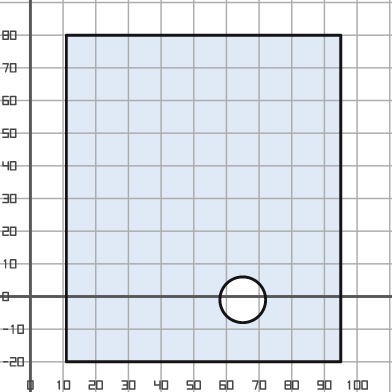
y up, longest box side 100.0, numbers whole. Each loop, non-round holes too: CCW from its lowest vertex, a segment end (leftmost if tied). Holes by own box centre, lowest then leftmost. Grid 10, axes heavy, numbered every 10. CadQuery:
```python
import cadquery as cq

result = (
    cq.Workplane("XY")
    .moveTo(11.0, -20.0)
    .lineTo(95.0, -20.0)
    .lineTo(95.0, 80.0)
    .lineTo(11.0, 80.0)
    .close()
    .moveTo(65.0, -1.0)
    .circle(7.0)
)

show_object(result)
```